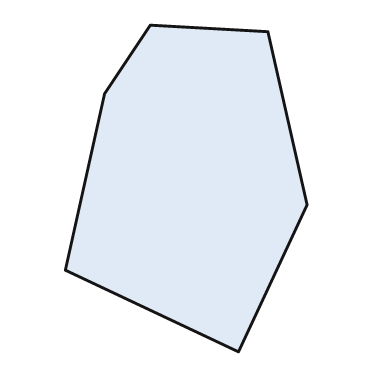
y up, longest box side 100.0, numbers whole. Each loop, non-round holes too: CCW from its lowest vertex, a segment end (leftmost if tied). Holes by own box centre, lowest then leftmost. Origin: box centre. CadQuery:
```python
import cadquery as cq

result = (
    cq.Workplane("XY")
    .moveTo(16.0, -50.0)
    .lineTo(37.0, -5.0)
    .lineTo(25.0, 48.0)
    .lineTo(-11.0, 50.0)
    .lineTo(-25.0, 29.0)
    .lineTo(-37.0, -25.0)
    .close()
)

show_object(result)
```